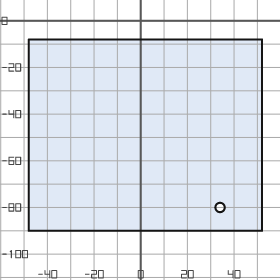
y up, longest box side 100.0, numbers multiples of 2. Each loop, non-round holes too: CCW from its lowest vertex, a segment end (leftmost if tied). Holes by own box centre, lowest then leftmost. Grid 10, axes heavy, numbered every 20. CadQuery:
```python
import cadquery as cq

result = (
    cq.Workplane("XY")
    .moveTo(-48.0, -90.0)
    .lineTo(52.0, -90.0)
    .lineTo(52.0, -8.0)
    .lineTo(-48.0, -8.0)
    .close()
    .moveTo(34.0, -80.0)
    .circle(2.0)
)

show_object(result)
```